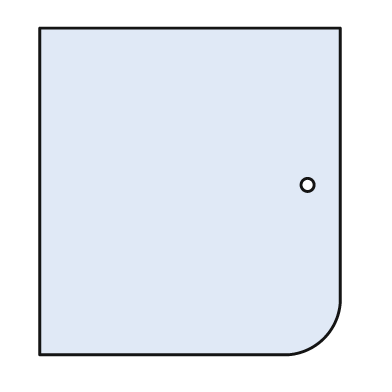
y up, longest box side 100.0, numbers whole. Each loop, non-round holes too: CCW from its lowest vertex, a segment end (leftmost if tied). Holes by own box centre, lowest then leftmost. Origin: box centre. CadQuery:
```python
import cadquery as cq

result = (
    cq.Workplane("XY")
    .moveTo(-46.0, -50.0)
    .lineTo(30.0, -50.0)
    .threePointArc((41.0, -45.0), (46.0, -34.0))
    .lineTo(46.0, 50.0)
    .lineTo(-46.0, 50.0)
    .close()
    .moveTo(36.0, 2.0)
    .circle(2.0)
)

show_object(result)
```